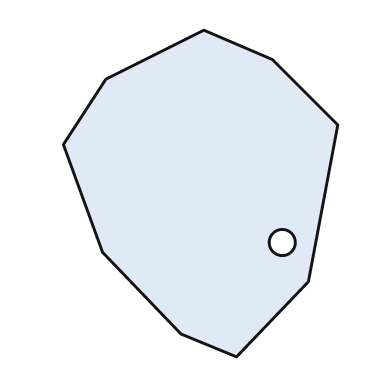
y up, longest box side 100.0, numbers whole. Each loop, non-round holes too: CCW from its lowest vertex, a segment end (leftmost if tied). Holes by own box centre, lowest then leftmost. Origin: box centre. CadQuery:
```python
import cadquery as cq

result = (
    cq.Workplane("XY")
    .moveTo(11.0, -50.0)
    .lineTo(33.0, -27.0)
    .lineTo(42.0, 21.0)
    .lineTo(22.0, 41.0)
    .lineTo(1.0, 50.0)
    .lineTo(-29.0, 35.0)
    .lineTo(-42.0, 15.0)
    .lineTo(-30.0, -18.0)
    .lineTo(-6.0, -43.0)
    .close()
    .moveTo(25.0, -15.0)
    .circle(4.0)
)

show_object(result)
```